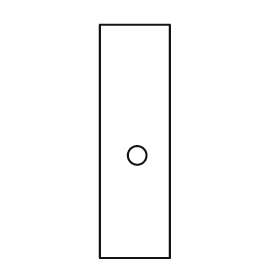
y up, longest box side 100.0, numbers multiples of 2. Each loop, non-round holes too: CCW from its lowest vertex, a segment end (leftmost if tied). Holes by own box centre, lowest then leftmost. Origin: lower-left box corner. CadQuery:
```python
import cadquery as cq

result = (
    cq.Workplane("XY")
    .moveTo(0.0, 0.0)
    .lineTo(30.0, 0.0)
    .lineTo(30.0, 100.0)
    .lineTo(0.0, 100.0)
    .close()
    .moveTo(16.0, 44.0)
    .circle(4.0)
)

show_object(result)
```